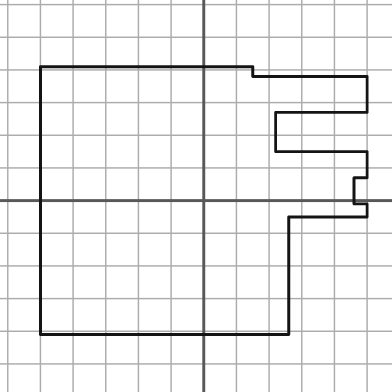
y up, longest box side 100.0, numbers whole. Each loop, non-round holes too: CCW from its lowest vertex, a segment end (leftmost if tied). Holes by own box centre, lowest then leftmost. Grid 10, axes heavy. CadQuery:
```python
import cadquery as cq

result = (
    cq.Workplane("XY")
    .moveTo(-50.0, -41.0)
    .lineTo(26.0, -41.0)
    .lineTo(26.0, -5.0)
    .lineTo(50.0, -5.0)
    .lineTo(50.0, -1.0)
    .lineTo(46.0, -1.0)
    .lineTo(46.0, 7.0)
    .lineTo(50.0, 7.0)
    .lineTo(50.0, 15.0)
    .lineTo(22.0, 15.0)
    .lineTo(22.0, 27.0)
    .lineTo(50.0, 27.0)
    .lineTo(50.0, 38.0)
    .lineTo(15.0, 38.0)
    .lineTo(15.0, 41.0)
    .lineTo(-50.0, 41.0)
    .close()
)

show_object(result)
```